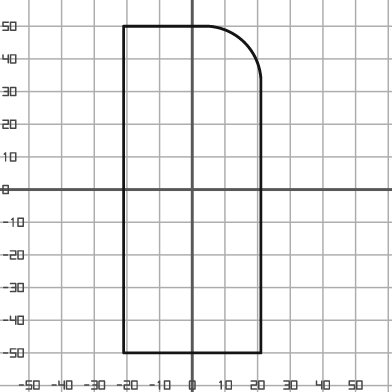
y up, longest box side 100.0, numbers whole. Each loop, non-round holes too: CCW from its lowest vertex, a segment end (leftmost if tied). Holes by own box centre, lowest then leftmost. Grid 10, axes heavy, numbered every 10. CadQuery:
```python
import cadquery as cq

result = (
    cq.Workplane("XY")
    .moveTo(-21.0, -50.0)
    .lineTo(21.0, -50.0)
    .lineTo(21.0, 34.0)
    .threePointArc((16.0, 45.0), (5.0, 50.0))
    .lineTo(-21.0, 50.0)
    .close()
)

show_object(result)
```